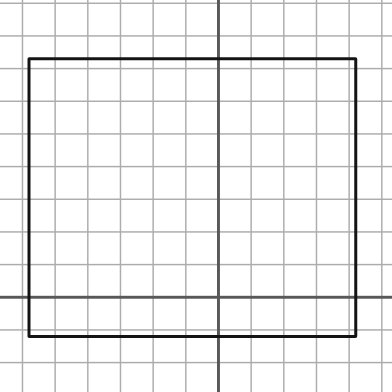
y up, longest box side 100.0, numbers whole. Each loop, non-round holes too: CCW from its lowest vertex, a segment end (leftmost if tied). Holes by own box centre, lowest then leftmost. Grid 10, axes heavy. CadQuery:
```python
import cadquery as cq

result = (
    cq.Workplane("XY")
    .moveTo(-58.0, -12.0)
    .lineTo(42.0, -12.0)
    .lineTo(42.0, 73.0)
    .lineTo(-58.0, 73.0)
    .close()
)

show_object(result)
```